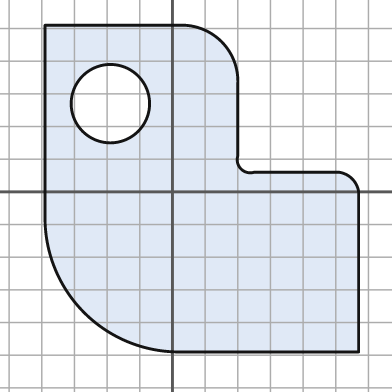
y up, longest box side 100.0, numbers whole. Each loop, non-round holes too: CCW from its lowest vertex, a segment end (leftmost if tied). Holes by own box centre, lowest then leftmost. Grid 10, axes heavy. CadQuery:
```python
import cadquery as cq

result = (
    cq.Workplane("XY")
    .moveTo(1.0, -49.0)
    .lineTo(57.0, -49.0)
    .lineTo(57.0, 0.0)
    .threePointArc((55.0, 4.0), (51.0, 6.0))
    .lineTo(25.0, 6.0)
    .threePointArc((21.0, 7.0), (20.0, 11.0))
    .lineTo(20.0, 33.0)
    .threePointArc((15.0, 46.0), (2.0, 51.0))
    .lineTo(-39.0, 51.0)
    .lineTo(-39.0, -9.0)
    .threePointArc((-27.0, -37.0), (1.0, -49.0))
    .close()
    .moveTo(-19.0, 27.0)
    .circle(12.0)
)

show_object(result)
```